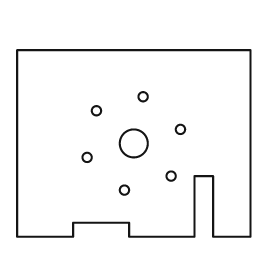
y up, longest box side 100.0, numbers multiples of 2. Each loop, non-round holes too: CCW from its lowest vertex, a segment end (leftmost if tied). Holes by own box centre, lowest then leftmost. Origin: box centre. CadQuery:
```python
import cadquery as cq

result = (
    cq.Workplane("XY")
    .moveTo(-50.0, -40.0)
    .lineTo(-26.0, -40.0)
    .lineTo(-26.0, -34.0)
    .lineTo(-2.0, -34.0)
    .lineTo(-2.0, -40.0)
    .lineTo(26.0, -40.0)
    .lineTo(26.0, -14.0)
    .lineTo(34.0, -14.0)
    .lineTo(34.0, -40.0)
    .lineTo(50.0, -40.0)
    .lineTo(50.0, 40.0)
    .lineTo(-50.0, 40.0)
    .close()
    .moveTo(-4.0, -20.0)
    .circle(2.0)
    .moveTo(16.0, -14.0)
    .circle(2.0)
    .moveTo(-20.0, -6.0)
    .circle(2.0)
    .moveTo(0.0, 0.0)
    .circle(6.0)
    .moveTo(20.0, 6.0)
    .circle(2.0)
    .moveTo(-16.0, 14.0)
    .circle(2.0)
    .moveTo(4.0, 20.0)
    .circle(2.0)
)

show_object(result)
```